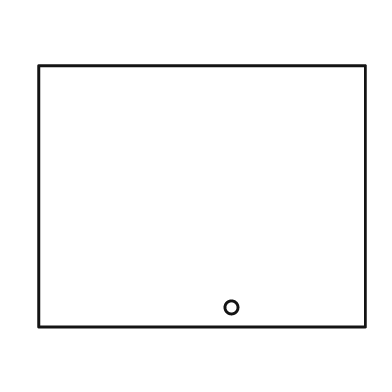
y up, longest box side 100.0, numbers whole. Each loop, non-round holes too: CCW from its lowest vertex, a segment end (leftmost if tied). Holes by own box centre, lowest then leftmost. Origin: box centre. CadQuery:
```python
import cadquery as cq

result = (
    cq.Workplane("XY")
    .moveTo(-50.0, -40.0)
    .lineTo(50.0, -40.0)
    .lineTo(50.0, 40.0)
    .lineTo(-50.0, 40.0)
    .close()
    .moveTo(9.0, -34.0)
    .circle(2.0)
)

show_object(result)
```